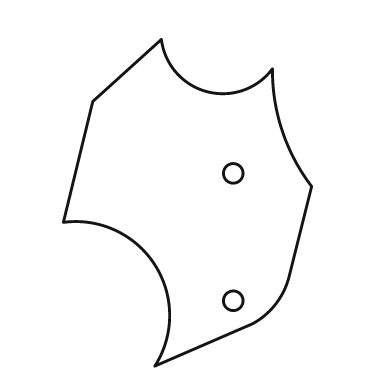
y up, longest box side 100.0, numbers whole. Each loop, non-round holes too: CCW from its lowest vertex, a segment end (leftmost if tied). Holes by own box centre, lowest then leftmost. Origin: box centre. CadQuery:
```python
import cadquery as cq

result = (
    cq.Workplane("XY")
    .moveTo(-10.0, -50.0)
    .lineTo(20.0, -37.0)
    .threePointArc((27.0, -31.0), (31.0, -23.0))
    .lineTo(38.0, 5.0)
    .threePointArc((29.0, 22.0), (26.0, 41.0))
    .threePointArc((6.0, 34.0), (-8.0, 50.0))
    .lineTo(-29.0, 31.0)
    .lineTo(-38.0, -6.0)
    .threePointArc((-10.0, -19.0), (-10.0, -50.0))
    .close()
    .moveTo(14.0, -30.0)
    .circle(3.0)
    .moveTo(14.0, 9.0)
    .circle(3.0)
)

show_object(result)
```